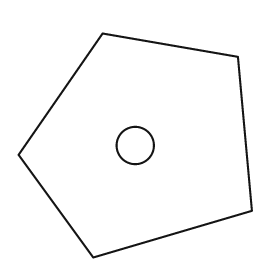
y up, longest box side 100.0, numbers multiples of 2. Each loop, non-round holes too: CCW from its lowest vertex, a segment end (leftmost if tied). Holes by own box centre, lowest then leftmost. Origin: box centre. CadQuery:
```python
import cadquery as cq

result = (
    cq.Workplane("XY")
    .moveTo(-18.0, -48.0)
    .lineTo(50.0, -28.0)
    .lineTo(44.0, 38.0)
    .lineTo(-14.0, 48.0)
    .lineTo(-50.0, -4.0)
    .close()
    .moveTo(0.0, 0.0)
    .circle(8.0)
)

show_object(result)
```